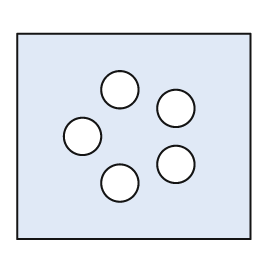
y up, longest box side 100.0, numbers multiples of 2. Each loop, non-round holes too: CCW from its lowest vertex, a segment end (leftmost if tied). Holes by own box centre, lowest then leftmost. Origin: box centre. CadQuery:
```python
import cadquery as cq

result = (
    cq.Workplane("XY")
    .moveTo(-50.0, -44.0)
    .lineTo(50.0, -44.0)
    .lineTo(50.0, 44.0)
    .lineTo(-50.0, 44.0)
    .close()
    .moveTo(-6.0, -20.0)
    .circle(8.0)
    .moveTo(18.0, -12.0)
    .circle(8.0)
    .moveTo(-22.0, 0.0)
    .circle(8.0)
    .moveTo(18.0, 12.0)
    .circle(8.0)
    .moveTo(-6.0, 20.0)
    .circle(8.0)
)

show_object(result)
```